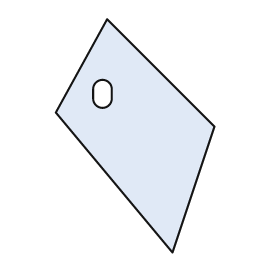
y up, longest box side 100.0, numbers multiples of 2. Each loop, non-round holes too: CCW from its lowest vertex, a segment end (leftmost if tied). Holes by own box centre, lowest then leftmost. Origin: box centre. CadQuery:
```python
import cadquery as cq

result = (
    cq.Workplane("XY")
    .moveTo(16.0, -50.0)
    .lineTo(34.0, 4.0)
    .lineTo(-12.0, 50.0)
    .lineTo(-34.0, 10.0)
    .close()
    .moveTo(-18.0, 16.0)
    .threePointArc((-14.0, 12.0), (-10.0, 16.0))
    .lineTo(-10.0, 20.0)
    .threePointArc((-14.0, 24.0), (-18.0, 20.0))
    .close()
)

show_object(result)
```